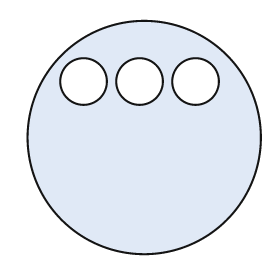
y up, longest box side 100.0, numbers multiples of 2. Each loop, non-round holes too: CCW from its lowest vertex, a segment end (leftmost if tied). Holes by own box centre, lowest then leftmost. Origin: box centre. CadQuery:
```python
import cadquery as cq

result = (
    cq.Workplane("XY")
    .moveTo(0.0, 0.0)
    .circle(50.0)
    .moveTo(-26.0, 24.0)
    .circle(10.0)
    .moveTo(-2.0, 24.0)
    .circle(10.0)
    .moveTo(22.0, 24.0)
    .circle(10.0)
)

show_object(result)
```